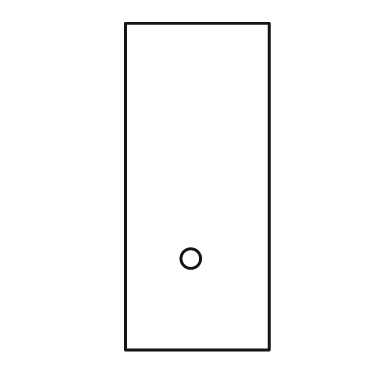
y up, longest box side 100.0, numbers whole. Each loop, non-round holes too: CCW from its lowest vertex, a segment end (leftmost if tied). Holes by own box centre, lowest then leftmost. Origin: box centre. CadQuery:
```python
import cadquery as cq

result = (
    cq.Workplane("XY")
    .moveTo(-22.0, -50.0)
    .lineTo(22.0, -50.0)
    .lineTo(22.0, 50.0)
    .lineTo(-22.0, 50.0)
    .close()
    .moveTo(-2.0, -22.0)
    .circle(3.0)
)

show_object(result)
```